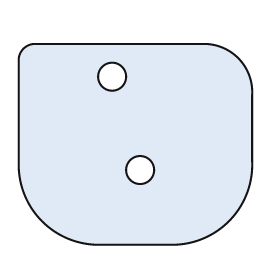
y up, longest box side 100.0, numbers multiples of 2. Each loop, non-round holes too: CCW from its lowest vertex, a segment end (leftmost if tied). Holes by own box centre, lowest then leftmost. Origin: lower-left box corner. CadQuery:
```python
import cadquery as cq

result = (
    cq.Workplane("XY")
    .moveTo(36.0, 0.0)
    .lineTo(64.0, 0.0)
    .threePointArc((90.0, 10.0), (100.0, 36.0))
    .lineTo(100.0, 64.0)
    .threePointArc((94.0, 80.0), (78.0, 86.0))
    .lineTo(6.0, 86.0)
    .threePointArc((2.0, 84.0), (0.0, 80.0))
    .lineTo(0.0, 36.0)
    .threePointArc((10.0, 10.0), (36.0, 0.0))
    .close()
    .moveTo(52.0, 32.0)
    .circle(6.0)
    .moveTo(40.0, 72.0)
    .circle(6.0)
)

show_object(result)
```